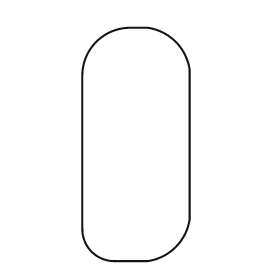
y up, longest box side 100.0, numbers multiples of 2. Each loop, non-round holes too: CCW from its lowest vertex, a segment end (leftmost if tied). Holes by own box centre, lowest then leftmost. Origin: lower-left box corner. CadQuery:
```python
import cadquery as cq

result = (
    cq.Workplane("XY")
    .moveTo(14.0, 0.0)
    .lineTo(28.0, 0.0)
    .threePointArc((40.0, 6.0), (46.0, 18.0))
    .lineTo(46.0, 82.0)
    .threePointArc((40.0, 94.0), (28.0, 100.0))
    .lineTo(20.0, 100.0)
    .threePointArc((6.0, 94.0), (0.0, 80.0))
    .lineTo(0.0, 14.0)
    .threePointArc((4.0, 4.0), (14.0, 0.0))
    .close()
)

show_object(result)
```